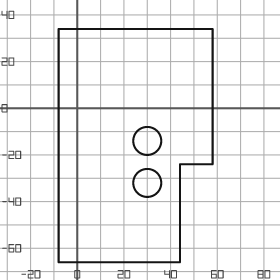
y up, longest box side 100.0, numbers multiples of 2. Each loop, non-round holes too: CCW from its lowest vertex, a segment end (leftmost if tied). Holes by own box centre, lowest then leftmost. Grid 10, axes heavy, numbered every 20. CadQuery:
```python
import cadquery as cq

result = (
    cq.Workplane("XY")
    .moveTo(-8.0, -66.0)
    .lineTo(44.0, -66.0)
    .lineTo(44.0, -24.0)
    .lineTo(58.0, -24.0)
    .lineTo(58.0, 34.0)
    .lineTo(-8.0, 34.0)
    .close()
    .moveTo(30.0, -32.0)
    .circle(6.0)
    .moveTo(30.0, -14.0)
    .circle(6.0)
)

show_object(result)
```